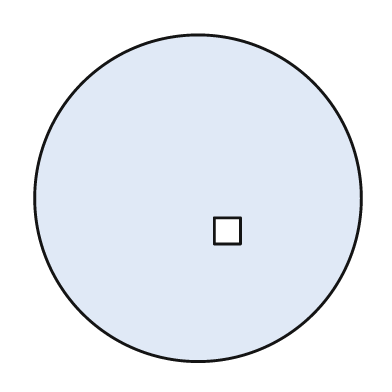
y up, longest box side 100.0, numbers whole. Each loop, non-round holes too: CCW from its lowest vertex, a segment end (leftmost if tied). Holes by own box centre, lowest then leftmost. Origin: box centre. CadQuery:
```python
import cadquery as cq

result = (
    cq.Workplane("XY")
    .moveTo(0.0, 0.0)
    .circle(50.0)
    .moveTo(5.0, -14.0)
    .lineTo(13.0, -14.0)
    .lineTo(13.0, -6.0)
    .lineTo(5.0, -6.0)
    .close()
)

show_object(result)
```